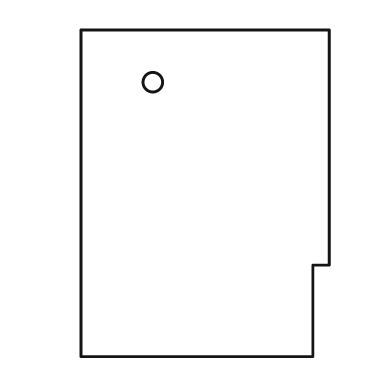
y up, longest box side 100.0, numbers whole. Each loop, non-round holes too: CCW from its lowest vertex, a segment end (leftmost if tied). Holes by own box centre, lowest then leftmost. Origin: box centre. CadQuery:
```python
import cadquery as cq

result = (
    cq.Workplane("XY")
    .moveTo(-38.0, -50.0)
    .lineTo(33.0, -50.0)
    .lineTo(33.0, -22.0)
    .lineTo(38.0, -22.0)
    .lineTo(38.0, 50.0)
    .lineTo(-38.0, 50.0)
    .close()
    .moveTo(-16.0, 34.0)
    .circle(3.0)
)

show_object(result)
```